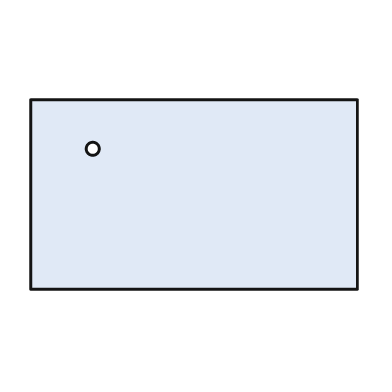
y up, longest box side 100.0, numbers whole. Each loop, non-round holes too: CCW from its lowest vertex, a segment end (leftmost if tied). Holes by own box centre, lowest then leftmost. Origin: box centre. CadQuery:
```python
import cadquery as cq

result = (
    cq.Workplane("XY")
    .moveTo(-50.0, -29.0)
    .lineTo(50.0, -29.0)
    .lineTo(50.0, 29.0)
    .lineTo(-50.0, 29.0)
    .close()
    .moveTo(-31.0, 14.0)
    .circle(2.0)
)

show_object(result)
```